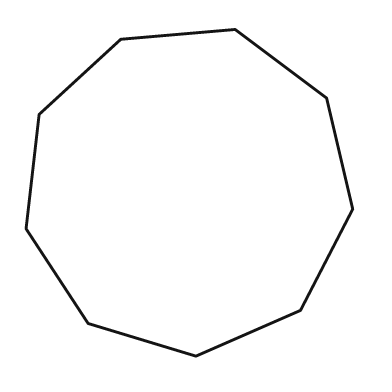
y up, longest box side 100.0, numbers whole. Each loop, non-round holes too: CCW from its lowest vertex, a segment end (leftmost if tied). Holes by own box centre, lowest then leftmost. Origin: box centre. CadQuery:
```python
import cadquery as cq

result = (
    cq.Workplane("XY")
    .moveTo(2.0, -50.0)
    .lineTo(34.0, -36.0)
    .lineTo(50.0, -5.0)
    .lineTo(42.0, 29.0)
    .lineTo(14.0, 50.0)
    .lineTo(-21.0, 47.0)
    .lineTo(-46.0, 24.0)
    .lineTo(-50.0, -11.0)
    .lineTo(-31.0, -40.0)
    .close()
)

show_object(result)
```